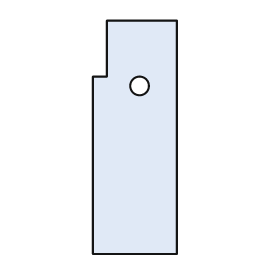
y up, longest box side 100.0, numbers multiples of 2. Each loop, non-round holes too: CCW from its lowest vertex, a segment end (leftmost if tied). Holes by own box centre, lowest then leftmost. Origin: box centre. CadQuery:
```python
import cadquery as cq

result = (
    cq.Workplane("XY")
    .moveTo(-18.0, -50.0)
    .lineTo(18.0, -50.0)
    .lineTo(18.0, 50.0)
    .lineTo(-12.0, 50.0)
    .lineTo(-12.0, 26.0)
    .lineTo(-18.0, 26.0)
    .close()
    .moveTo(2.0, 22.0)
    .circle(4.0)
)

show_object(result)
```